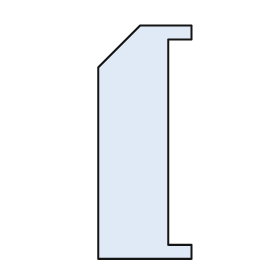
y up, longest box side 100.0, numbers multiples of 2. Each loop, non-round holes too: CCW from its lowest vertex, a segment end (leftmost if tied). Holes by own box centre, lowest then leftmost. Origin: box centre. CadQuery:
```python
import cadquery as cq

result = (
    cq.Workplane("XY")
    .moveTo(-20.0, -50.0)
    .lineTo(20.0, -50.0)
    .lineTo(20.0, -44.0)
    .lineTo(10.0, -44.0)
    .lineTo(10.0, 44.0)
    .lineTo(20.0, 44.0)
    .lineTo(20.0, 50.0)
    .lineTo(-2.0, 50.0)
    .lineTo(-20.0, 32.0)
    .close()
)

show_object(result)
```